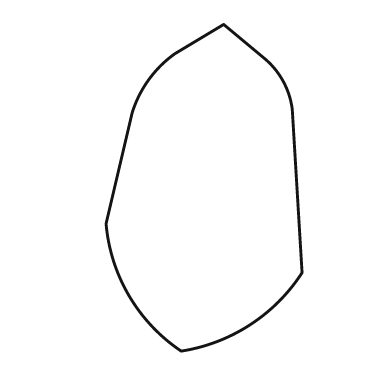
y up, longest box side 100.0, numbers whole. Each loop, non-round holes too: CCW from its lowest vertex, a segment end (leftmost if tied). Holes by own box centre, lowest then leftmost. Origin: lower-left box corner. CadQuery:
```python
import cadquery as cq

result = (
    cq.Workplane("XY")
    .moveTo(23.0, 0.0)
    .threePointArc((44.0, 8.0), (60.0, 24.0))
    .lineTo(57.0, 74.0)
    .threePointArc((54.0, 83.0), (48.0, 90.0))
    .lineTo(36.0, 100.0)
    .lineTo(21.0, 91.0)
    .threePointArc((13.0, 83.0), (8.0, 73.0))
    .lineTo(0.0, 39.0)
    .threePointArc((7.0, 17.0), (23.0, 0.0))
    .close()
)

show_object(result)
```